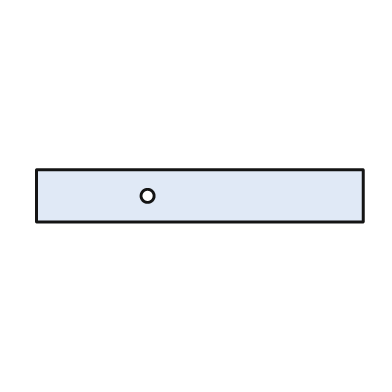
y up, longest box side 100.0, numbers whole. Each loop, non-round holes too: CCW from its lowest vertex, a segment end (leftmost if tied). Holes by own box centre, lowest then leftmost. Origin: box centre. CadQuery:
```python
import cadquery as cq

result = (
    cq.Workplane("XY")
    .moveTo(-50.0, -8.0)
    .lineTo(50.0, -8.0)
    .lineTo(50.0, 8.0)
    .lineTo(-50.0, 8.0)
    .close()
    .moveTo(-16.0, 0.0)
    .circle(2.0)
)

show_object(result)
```